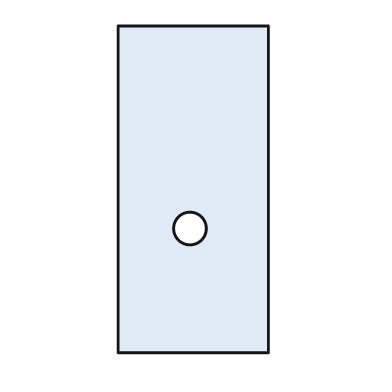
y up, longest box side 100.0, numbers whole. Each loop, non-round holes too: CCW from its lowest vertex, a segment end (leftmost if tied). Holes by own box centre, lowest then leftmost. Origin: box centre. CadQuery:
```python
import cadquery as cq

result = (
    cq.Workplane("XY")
    .moveTo(-23.0, -50.0)
    .lineTo(23.0, -50.0)
    .lineTo(23.0, 50.0)
    .lineTo(-23.0, 50.0)
    .close()
    .moveTo(-1.0, -12.0)
    .circle(5.0)
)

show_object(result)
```